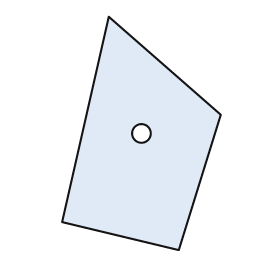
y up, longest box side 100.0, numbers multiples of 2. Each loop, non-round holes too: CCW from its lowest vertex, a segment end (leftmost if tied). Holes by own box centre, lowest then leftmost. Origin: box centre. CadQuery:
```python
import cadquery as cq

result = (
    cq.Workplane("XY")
    .moveTo(16.0, -50.0)
    .lineTo(34.0, 8.0)
    .lineTo(-14.0, 50.0)
    .lineTo(-34.0, -38.0)
    .close()
    .moveTo(0.0, 0.0)
    .circle(4.0)
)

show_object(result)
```